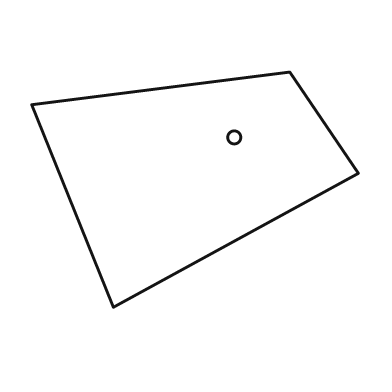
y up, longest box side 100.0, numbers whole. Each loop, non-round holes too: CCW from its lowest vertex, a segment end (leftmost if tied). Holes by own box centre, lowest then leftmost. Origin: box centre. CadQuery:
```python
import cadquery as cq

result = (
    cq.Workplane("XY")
    .moveTo(-25.0, -36.0)
    .lineTo(50.0, 5.0)
    .lineTo(29.0, 36.0)
    .lineTo(-50.0, 26.0)
    .close()
    .moveTo(12.0, 16.0)
    .circle(2.0)
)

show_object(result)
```